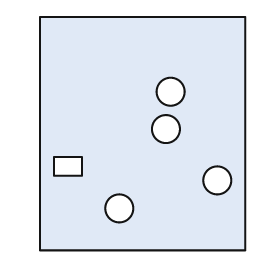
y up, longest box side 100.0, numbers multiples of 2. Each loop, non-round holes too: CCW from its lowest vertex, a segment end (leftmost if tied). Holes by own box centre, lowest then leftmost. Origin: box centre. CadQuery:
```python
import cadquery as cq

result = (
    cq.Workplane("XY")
    .moveTo(-44.0, -50.0)
    .lineTo(44.0, -50.0)
    .lineTo(44.0, 50.0)
    .lineTo(-44.0, 50.0)
    .close()
    .moveTo(-10.0, -32.0)
    .circle(6.0)
    .moveTo(32.0, -20.0)
    .circle(6.0)
    .moveTo(-38.0, -18.0)
    .lineTo(-26.0, -18.0)
    .lineTo(-26.0, -10.0)
    .lineTo(-38.0, -10.0)
    .close()
    .moveTo(10.0, 2.0)
    .circle(6.0)
    .moveTo(12.0, 18.0)
    .circle(6.0)
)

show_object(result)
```